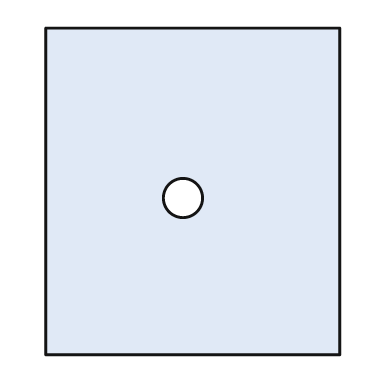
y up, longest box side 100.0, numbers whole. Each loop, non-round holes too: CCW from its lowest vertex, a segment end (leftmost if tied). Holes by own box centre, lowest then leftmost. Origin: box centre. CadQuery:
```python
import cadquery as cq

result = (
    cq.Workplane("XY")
    .moveTo(-45.0, -50.0)
    .lineTo(45.0, -50.0)
    .lineTo(45.0, 50.0)
    .lineTo(-45.0, 50.0)
    .close()
    .moveTo(-3.0, -2.0)
    .circle(6.0)
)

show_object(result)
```